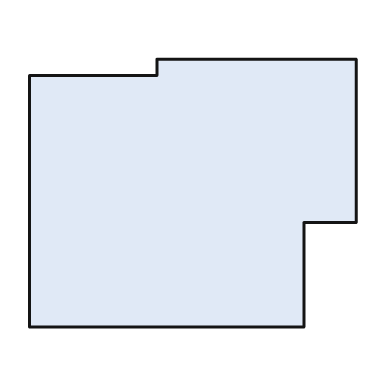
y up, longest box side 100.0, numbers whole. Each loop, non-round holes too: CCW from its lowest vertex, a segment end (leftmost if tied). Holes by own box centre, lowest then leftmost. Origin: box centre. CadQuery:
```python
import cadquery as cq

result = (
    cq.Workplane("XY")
    .moveTo(-50.0, -41.0)
    .lineTo(34.0, -41.0)
    .lineTo(34.0, -9.0)
    .lineTo(50.0, -9.0)
    .lineTo(50.0, 41.0)
    .lineTo(-11.0, 41.0)
    .lineTo(-11.0, 36.0)
    .lineTo(-50.0, 36.0)
    .close()
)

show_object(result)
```